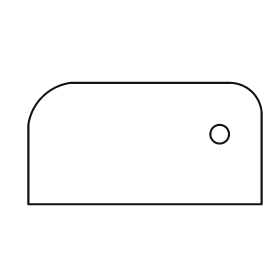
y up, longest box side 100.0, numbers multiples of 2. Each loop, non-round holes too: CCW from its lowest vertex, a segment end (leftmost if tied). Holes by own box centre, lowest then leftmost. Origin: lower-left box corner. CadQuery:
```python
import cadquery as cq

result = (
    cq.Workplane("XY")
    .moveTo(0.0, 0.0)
    .lineTo(100.0, 0.0)
    .lineTo(100.0, 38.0)
    .threePointArc((96.0, 48.0), (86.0, 52.0))
    .lineTo(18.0, 52.0)
    .threePointArc((6.0, 46.0), (0.0, 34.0))
    .close()
    .moveTo(82.0, 30.0)
    .circle(4.0)
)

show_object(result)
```